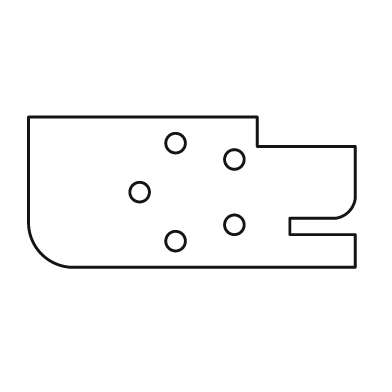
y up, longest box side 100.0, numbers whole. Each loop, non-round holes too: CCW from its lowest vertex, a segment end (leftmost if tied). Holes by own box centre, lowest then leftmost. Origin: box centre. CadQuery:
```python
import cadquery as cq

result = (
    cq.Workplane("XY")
    .moveTo(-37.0, -23.0)
    .lineTo(50.0, -23.0)
    .lineTo(50.0, -13.0)
    .lineTo(30.0, -13.0)
    .lineTo(30.0, -8.0)
    .lineTo(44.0, -8.0)
    .threePointArc((48.0, -6.0), (50.0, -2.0))
    .lineTo(50.0, 14.0)
    .lineTo(20.0, 14.0)
    .lineTo(20.0, 23.0)
    .lineTo(-50.0, 23.0)
    .lineTo(-50.0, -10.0)
    .threePointArc((-46.0, -19.0), (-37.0, -23.0))
    .close()
    .moveTo(-5.0, -15.0)
    .circle(3.0)
    .moveTo(13.0, -10.0)
    .circle(3.0)
    .moveTo(-16.0, 0.0)
    .circle(3.0)
    .moveTo(13.0, 10.0)
    .circle(3.0)
    .moveTo(-5.0, 15.0)
    .circle(3.0)
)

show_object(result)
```